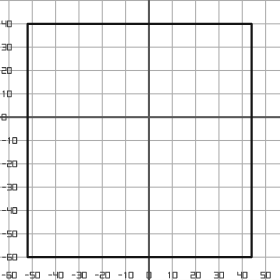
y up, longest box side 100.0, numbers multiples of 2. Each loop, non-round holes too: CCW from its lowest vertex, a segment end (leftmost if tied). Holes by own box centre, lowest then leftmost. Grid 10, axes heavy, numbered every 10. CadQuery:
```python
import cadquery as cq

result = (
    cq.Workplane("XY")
    .moveTo(-52.0, -60.0)
    .lineTo(44.0, -60.0)
    .lineTo(44.0, 40.0)
    .lineTo(-52.0, 40.0)
    .close()
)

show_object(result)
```